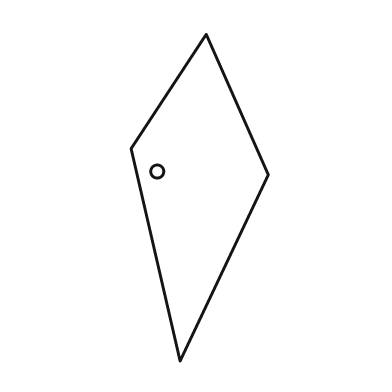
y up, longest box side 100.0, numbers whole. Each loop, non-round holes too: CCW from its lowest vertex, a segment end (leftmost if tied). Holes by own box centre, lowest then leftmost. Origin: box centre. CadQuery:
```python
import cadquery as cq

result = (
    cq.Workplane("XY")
    .moveTo(-6.0, -50.0)
    .lineTo(21.0, 7.0)
    .lineTo(2.0, 50.0)
    .lineTo(-21.0, 15.0)
    .close()
    .moveTo(-13.0, 8.0)
    .circle(2.0)
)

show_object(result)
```